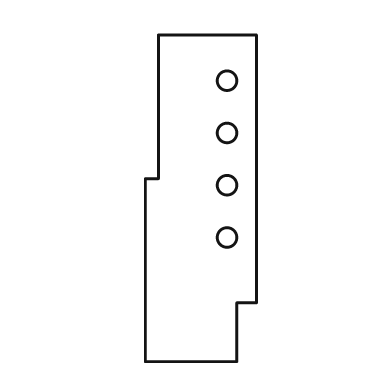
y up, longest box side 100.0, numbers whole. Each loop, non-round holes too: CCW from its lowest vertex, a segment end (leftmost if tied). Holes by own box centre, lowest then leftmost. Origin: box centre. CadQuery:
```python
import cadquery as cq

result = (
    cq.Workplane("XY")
    .moveTo(-17.0, -50.0)
    .lineTo(11.0, -50.0)
    .lineTo(11.0, -32.0)
    .lineTo(17.0, -32.0)
    .lineTo(17.0, 50.0)
    .lineTo(-13.0, 50.0)
    .lineTo(-13.0, 6.0)
    .lineTo(-17.0, 6.0)
    .close()
    .moveTo(8.0, -12.0)
    .circle(3.0)
    .moveTo(8.0, 4.0)
    .circle(3.0)
    .moveTo(8.0, 20.0)
    .circle(3.0)
    .moveTo(8.0, 36.0)
    .circle(3.0)
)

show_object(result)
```